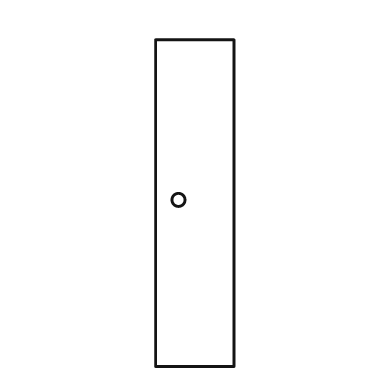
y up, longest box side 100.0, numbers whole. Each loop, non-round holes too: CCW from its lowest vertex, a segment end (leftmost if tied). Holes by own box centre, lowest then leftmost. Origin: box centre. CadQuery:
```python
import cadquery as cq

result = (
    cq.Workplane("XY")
    .moveTo(-12.0, -50.0)
    .lineTo(12.0, -50.0)
    .lineTo(12.0, 50.0)
    .lineTo(-12.0, 50.0)
    .close()
    .moveTo(-5.0, 1.0)
    .circle(2.0)
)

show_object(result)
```